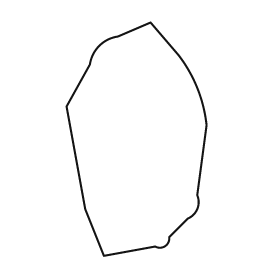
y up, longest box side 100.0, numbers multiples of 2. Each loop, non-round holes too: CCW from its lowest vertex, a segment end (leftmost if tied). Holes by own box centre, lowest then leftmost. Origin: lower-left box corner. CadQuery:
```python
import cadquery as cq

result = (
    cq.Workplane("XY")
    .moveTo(16.0, 0.0)
    .lineTo(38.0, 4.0)
    .threePointArc((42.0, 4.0), (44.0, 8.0))
    .lineTo(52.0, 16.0)
    .threePointArc((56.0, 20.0), (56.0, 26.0))
    .lineTo(60.0, 56.0)
    .threePointArc((56.0, 72.0), (48.0, 86.0))
    .lineTo(36.0, 100.0)
    .lineTo(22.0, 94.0)
    .threePointArc((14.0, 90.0), (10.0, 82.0))
    .lineTo(0.0, 64.0)
    .lineTo(8.0, 20.0)
    .close()
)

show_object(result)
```